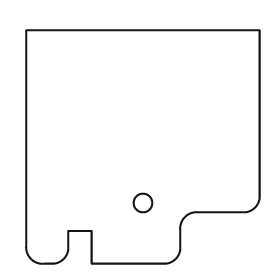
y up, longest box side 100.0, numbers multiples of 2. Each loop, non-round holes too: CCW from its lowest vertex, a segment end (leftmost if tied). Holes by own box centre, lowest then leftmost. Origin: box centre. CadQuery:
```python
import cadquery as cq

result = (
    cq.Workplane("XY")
    .moveTo(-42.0, -50.0)
    .lineTo(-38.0, -50.0)
    .threePointArc((-34.0, -48.0), (-32.0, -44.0))
    .lineTo(-32.0, -36.0)
    .lineTo(-22.0, -36.0)
    .lineTo(-22.0, -50.0)
    .lineTo(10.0, -50.0)
    .threePointArc((14.0, -48.0), (16.0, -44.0))
    .lineTo(16.0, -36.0)
    .threePointArc((18.0, -30.0), (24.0, -28.0))
    .lineTo(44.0, -28.0)
    .threePointArc((48.0, -26.0), (50.0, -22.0))
    .lineTo(50.0, 50.0)
    .lineTo(-50.0, 50.0)
    .lineTo(-50.0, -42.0)
    .threePointArc((-48.0, -48.0), (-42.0, -50.0))
    .close()
    .moveTo(0.0, -24.0)
    .circle(4.0)
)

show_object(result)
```